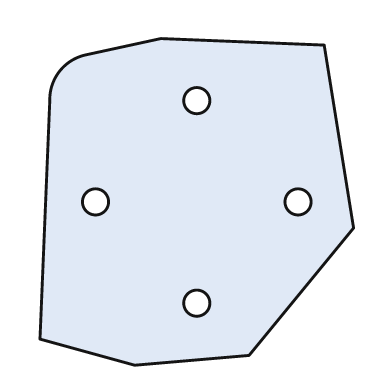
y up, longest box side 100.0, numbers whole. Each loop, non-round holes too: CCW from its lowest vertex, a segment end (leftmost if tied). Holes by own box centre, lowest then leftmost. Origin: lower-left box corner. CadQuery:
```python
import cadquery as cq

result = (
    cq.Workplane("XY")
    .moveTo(29.0, 0.0)
    .lineTo(64.0, 3.0)
    .lineTo(96.0, 42.0)
    .lineTo(87.0, 98.0)
    .lineTo(37.0, 100.0)
    .lineTo(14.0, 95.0)
    .threePointArc((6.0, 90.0), (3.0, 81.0))
    .lineTo(0.0, 8.0)
    .close()
    .moveTo(48.0, 19.0)
    .circle(4.0)
    .moveTo(17.0, 50.0)
    .circle(4.0)
    .moveTo(79.0, 50.0)
    .circle(4.0)
    .moveTo(48.0, 81.0)
    .circle(4.0)
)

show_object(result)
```